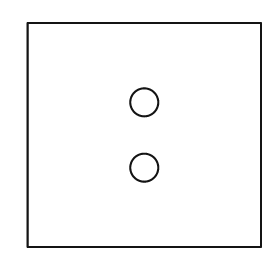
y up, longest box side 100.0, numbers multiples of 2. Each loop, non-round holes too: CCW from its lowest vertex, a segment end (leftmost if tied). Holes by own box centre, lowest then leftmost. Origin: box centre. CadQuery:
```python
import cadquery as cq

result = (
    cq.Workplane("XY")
    .moveTo(-50.0, -48.0)
    .lineTo(50.0, -48.0)
    .lineTo(50.0, 48.0)
    .lineTo(-50.0, 48.0)
    .close()
    .moveTo(0.0, -14.0)
    .circle(6.0)
    .moveTo(0.0, 14.0)
    .circle(6.0)
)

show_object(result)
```